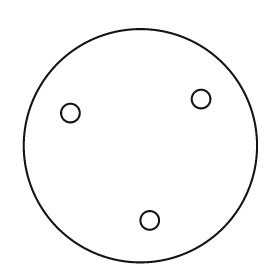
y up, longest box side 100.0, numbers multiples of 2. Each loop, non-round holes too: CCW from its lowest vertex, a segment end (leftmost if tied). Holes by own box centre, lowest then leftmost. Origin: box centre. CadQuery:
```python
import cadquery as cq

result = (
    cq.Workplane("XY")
    .moveTo(0.0, 0.0)
    .circle(50.0)
    .moveTo(4.0, -32.0)
    .circle(4.0)
    .moveTo(-30.0, 14.0)
    .circle(4.0)
    .moveTo(26.0, 20.0)
    .circle(4.0)
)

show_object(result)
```